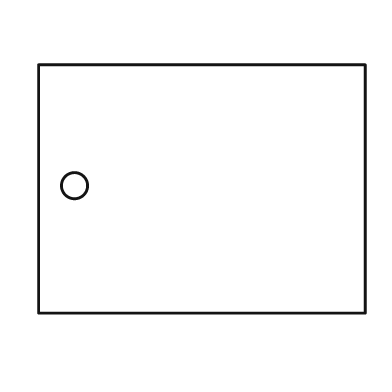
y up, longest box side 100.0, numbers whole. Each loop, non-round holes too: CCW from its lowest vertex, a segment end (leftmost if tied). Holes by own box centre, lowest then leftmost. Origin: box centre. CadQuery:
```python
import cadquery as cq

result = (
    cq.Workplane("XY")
    .moveTo(-50.0, -38.0)
    .lineTo(50.0, -38.0)
    .lineTo(50.0, 38.0)
    .lineTo(-50.0, 38.0)
    .close()
    .moveTo(-39.0, 1.0)
    .circle(4.0)
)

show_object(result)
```